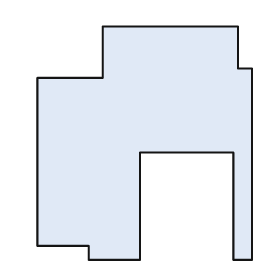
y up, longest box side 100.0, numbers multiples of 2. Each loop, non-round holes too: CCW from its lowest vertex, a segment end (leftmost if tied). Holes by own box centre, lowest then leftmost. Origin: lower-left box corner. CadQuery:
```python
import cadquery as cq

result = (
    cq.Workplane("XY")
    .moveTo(22.0, 0.0)
    .lineTo(44.0, 0.0)
    .lineTo(44.0, 46.0)
    .lineTo(84.0, 46.0)
    .lineTo(84.0, 0.0)
    .lineTo(92.0, 0.0)
    .lineTo(92.0, 82.0)
    .lineTo(86.0, 82.0)
    .lineTo(86.0, 100.0)
    .lineTo(28.0, 100.0)
    .lineTo(28.0, 78.0)
    .lineTo(0.0, 78.0)
    .lineTo(0.0, 6.0)
    .lineTo(22.0, 6.0)
    .close()
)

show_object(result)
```